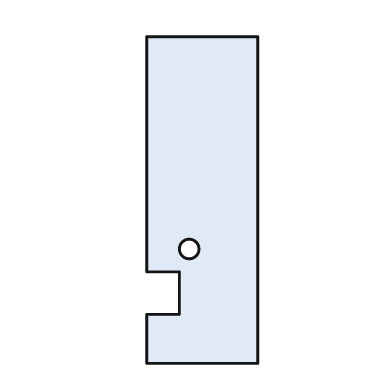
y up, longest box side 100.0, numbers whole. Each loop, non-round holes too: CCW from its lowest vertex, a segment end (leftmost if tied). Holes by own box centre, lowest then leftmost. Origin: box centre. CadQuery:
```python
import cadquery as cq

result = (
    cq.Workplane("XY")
    .moveTo(-17.0, -50.0)
    .lineTo(17.0, -50.0)
    .lineTo(17.0, 50.0)
    .lineTo(-17.0, 50.0)
    .lineTo(-17.0, -22.0)
    .lineTo(-7.0, -22.0)
    .lineTo(-7.0, -35.0)
    .lineTo(-17.0, -35.0)
    .close()
    .moveTo(-4.0, -15.0)
    .circle(3.0)
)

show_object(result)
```